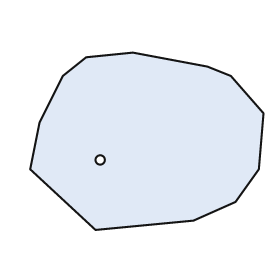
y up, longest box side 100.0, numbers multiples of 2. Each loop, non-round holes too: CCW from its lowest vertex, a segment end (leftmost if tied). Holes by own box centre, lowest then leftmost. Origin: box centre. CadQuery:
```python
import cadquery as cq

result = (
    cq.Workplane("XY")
    .moveTo(-22.0, -38.0)
    .lineTo(20.0, -34.0)
    .lineTo(38.0, -26.0)
    .lineTo(48.0, -12.0)
    .lineTo(50.0, 12.0)
    .lineTo(36.0, 28.0)
    .lineTo(26.0, 32.0)
    .lineTo(-6.0, 38.0)
    .lineTo(-26.0, 36.0)
    .lineTo(-36.0, 28.0)
    .lineTo(-46.0, 8.0)
    .lineTo(-50.0, -12.0)
    .close()
    .moveTo(-20.0, -8.0)
    .circle(2.0)
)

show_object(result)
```